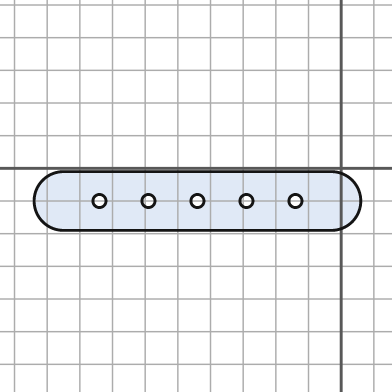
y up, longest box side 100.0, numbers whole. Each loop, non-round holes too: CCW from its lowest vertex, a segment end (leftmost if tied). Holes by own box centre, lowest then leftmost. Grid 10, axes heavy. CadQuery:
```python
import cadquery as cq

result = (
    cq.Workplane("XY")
    .moveTo(-85.0, -19.0)
    .lineTo(-3.0, -19.0)
    .threePointArc((6.0, -10.0), (-3.0, -1.0))
    .lineTo(-85.0, -1.0)
    .threePointArc((-94.0, -10.0), (-85.0, -19.0))
    .close()
    .moveTo(-74.0, -10.0)
    .circle(2.0)
    .moveTo(-59.0, -10.0)
    .circle(2.0)
    .moveTo(-44.0, -10.0)
    .circle(2.0)
    .moveTo(-29.0, -10.0)
    .circle(2.0)
    .moveTo(-14.0, -10.0)
    .circle(2.0)
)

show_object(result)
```